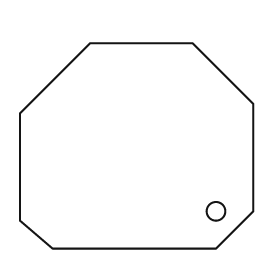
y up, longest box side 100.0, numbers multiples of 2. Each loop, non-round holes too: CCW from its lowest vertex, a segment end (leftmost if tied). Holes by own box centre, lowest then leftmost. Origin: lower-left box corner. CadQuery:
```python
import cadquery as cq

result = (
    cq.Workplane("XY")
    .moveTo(14.0, 0.0)
    .lineTo(84.0, 0.0)
    .lineTo(100.0, 16.0)
    .lineTo(100.0, 62.0)
    .lineTo(74.0, 88.0)
    .lineTo(30.0, 88.0)
    .lineTo(0.0, 58.0)
    .lineTo(0.0, 12.0)
    .close()
    .moveTo(84.0, 16.0)
    .circle(4.0)
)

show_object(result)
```